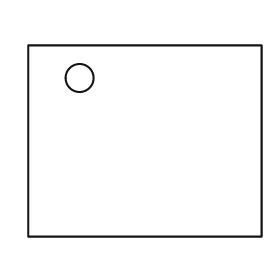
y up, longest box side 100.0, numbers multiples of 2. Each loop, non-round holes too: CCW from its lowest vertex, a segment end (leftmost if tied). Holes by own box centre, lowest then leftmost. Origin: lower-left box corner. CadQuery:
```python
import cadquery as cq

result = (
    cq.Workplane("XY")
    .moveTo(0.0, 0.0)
    .lineTo(100.0, 0.0)
    .lineTo(100.0, 82.0)
    .lineTo(0.0, 82.0)
    .close()
    .moveTo(22.0, 68.0)
    .circle(6.0)
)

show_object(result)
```